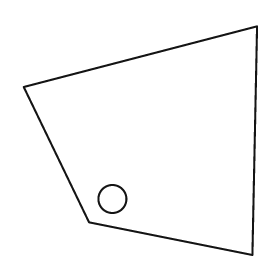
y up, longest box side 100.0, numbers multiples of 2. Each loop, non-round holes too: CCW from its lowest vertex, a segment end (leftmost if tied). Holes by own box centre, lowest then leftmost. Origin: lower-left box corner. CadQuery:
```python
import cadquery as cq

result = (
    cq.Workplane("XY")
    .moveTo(98.0, 0.0)
    .lineTo(100.0, 98.0)
    .lineTo(0.0, 72.0)
    .lineTo(28.0, 14.0)
    .close()
    .moveTo(38.0, 24.0)
    .circle(6.0)
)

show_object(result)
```